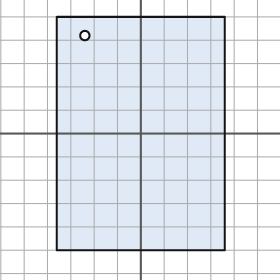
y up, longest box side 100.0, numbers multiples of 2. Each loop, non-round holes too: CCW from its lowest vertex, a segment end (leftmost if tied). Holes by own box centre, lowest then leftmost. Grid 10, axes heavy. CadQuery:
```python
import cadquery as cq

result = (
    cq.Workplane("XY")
    .moveTo(-36.0, -50.0)
    .lineTo(36.0, -50.0)
    .lineTo(36.0, 50.0)
    .lineTo(-36.0, 50.0)
    .close()
    .moveTo(-24.0, 42.0)
    .circle(2.0)
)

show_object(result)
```